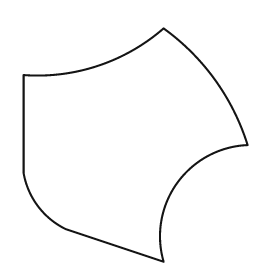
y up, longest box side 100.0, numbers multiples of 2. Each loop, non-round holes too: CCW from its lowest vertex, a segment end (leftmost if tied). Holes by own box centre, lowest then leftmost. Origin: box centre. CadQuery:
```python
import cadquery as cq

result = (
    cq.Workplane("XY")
    .moveTo(12.0, -50.0)
    .threePointArc((18.0, -16.0), (48.0, 0.0))
    .threePointArc((34.0, 28.0), (12.0, 50.0))
    .threePointArc((-16.0, 34.0), (-48.0, 30.0))
    .lineTo(-48.0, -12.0)
    .threePointArc((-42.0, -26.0), (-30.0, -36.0))
    .close()
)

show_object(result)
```